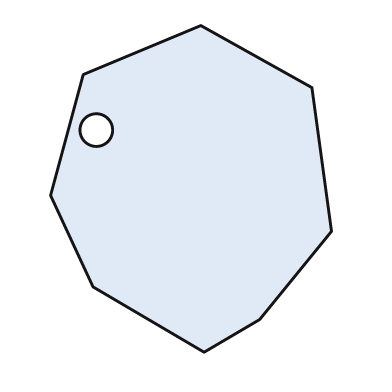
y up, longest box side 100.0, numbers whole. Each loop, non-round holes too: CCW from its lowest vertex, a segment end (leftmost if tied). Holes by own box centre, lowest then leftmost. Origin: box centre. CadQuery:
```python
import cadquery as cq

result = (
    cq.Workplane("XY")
    .moveTo(4.0, -50.0)
    .lineTo(21.0, -40.0)
    .lineTo(43.0, -13.0)
    .lineTo(37.0, 31.0)
    .lineTo(3.0, 50.0)
    .lineTo(-33.0, 35.0)
    .lineTo(-43.0, -2.0)
    .lineTo(-30.0, -30.0)
    .close()
    .moveTo(-29.0, 18.0)
    .circle(5.0)
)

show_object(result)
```